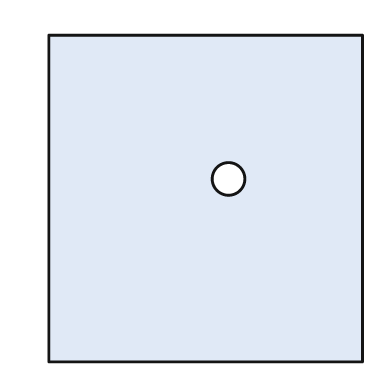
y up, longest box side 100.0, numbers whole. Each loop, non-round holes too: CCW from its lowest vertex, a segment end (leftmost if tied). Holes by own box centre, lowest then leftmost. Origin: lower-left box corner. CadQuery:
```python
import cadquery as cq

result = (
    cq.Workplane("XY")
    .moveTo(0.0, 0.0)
    .lineTo(96.0, 0.0)
    .lineTo(96.0, 100.0)
    .lineTo(0.0, 100.0)
    .close()
    .moveTo(55.0, 56.0)
    .circle(5.0)
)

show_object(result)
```